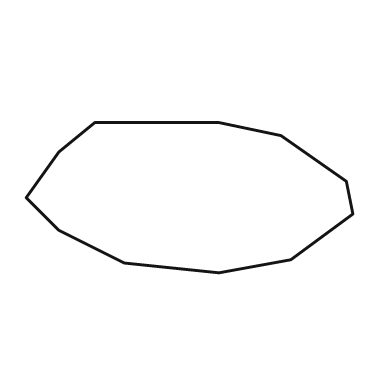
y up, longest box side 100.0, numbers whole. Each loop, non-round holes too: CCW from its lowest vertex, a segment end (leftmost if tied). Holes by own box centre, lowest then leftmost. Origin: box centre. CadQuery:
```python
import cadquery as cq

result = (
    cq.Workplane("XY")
    .moveTo(9.0, -23.0)
    .lineTo(31.0, -19.0)
    .lineTo(50.0, -5.0)
    .lineTo(48.0, 5.0)
    .lineTo(28.0, 19.0)
    .lineTo(9.0, 23.0)
    .lineTo(-29.0, 23.0)
    .lineTo(-40.0, 14.0)
    .lineTo(-50.0, 0.0)
    .lineTo(-40.0, -10.0)
    .lineTo(-20.0, -20.0)
    .close()
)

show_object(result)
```